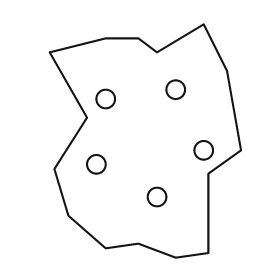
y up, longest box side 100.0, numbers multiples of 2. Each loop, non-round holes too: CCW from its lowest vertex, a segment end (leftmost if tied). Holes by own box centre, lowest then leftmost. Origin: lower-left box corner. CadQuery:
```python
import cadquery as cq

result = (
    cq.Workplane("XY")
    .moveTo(54.0, 0.0)
    .lineTo(68.0, 2.0)
    .lineTo(68.0, 36.0)
    .lineTo(82.0, 46.0)
    .lineTo(76.0, 80.0)
    .lineTo(66.0, 100.0)
    .lineTo(46.0, 88.0)
    .lineTo(38.0, 94.0)
    .lineTo(24.0, 94.0)
    .lineTo(0.0, 88.0)
    .lineTo(16.0, 60.0)
    .lineTo(2.0, 38.0)
    .lineTo(8.0, 18.0)
    .lineTo(24.0, 4.0)
    .lineTo(38.0, 6.0)
    .close()
    .moveTo(46.0, 26.0)
    .circle(4.0)
    .moveTo(20.0, 40.0)
    .circle(4.0)
    .moveTo(66.0, 46.0)
    .circle(4.0)
    .moveTo(24.0, 68.0)
    .circle(4.0)
    .moveTo(54.0, 72.0)
    .circle(4.0)
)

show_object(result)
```